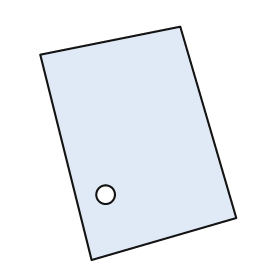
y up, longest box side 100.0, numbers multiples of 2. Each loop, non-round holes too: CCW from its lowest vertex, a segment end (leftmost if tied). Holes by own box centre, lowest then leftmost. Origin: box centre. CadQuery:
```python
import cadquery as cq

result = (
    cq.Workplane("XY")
    .moveTo(-20.0, -50.0)
    .lineTo(42.0, -32.0)
    .lineTo(18.0, 50.0)
    .lineTo(-42.0, 38.0)
    .close()
    .moveTo(-14.0, -22.0)
    .circle(4.0)
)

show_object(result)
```